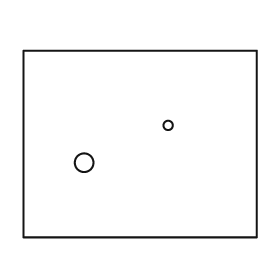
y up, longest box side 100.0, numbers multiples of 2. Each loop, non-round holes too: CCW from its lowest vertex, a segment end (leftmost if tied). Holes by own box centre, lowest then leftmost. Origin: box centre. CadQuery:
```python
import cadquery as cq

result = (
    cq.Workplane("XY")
    .moveTo(-50.0, -40.0)
    .lineTo(50.0, -40.0)
    .lineTo(50.0, 40.0)
    .lineTo(-50.0, 40.0)
    .close()
    .moveTo(-24.0, -8.0)
    .circle(4.0)
    .moveTo(12.0, 8.0)
    .circle(2.0)
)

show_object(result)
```